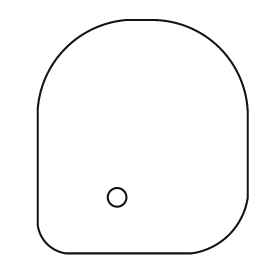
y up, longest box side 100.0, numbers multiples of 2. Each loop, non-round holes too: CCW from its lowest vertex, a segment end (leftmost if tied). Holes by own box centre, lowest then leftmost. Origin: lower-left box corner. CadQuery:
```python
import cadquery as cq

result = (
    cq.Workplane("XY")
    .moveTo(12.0, 0.0)
    .lineTo(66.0, 0.0)
    .threePointArc((82.0, 8.0), (90.0, 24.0))
    .lineTo(90.0, 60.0)
    .threePointArc((78.0, 88.0), (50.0, 100.0))
    .lineTo(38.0, 100.0)
    .threePointArc((12.0, 88.0), (0.0, 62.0))
    .lineTo(0.0, 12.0)
    .threePointArc((4.0, 4.0), (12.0, 0.0))
    .close()
    .moveTo(34.0, 24.0)
    .circle(4.0)
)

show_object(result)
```